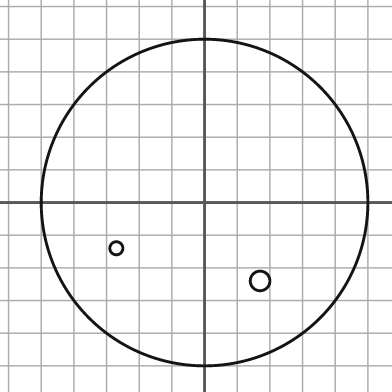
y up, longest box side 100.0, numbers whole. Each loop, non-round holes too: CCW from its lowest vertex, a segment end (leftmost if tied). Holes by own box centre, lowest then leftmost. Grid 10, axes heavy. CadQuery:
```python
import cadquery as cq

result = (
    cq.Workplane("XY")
    .moveTo(0.0, 0.0)
    .circle(50.0)
    .moveTo(17.0, -24.0)
    .circle(3.0)
    .moveTo(-27.0, -14.0)
    .circle(2.0)
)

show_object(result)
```